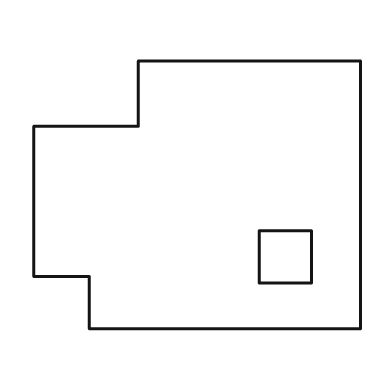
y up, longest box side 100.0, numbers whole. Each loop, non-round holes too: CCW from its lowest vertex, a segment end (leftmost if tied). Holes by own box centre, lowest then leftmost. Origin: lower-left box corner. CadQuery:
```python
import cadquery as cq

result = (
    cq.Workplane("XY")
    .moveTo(17.0, 0.0)
    .lineTo(100.0, 0.0)
    .lineTo(100.0, 82.0)
    .lineTo(32.0, 82.0)
    .lineTo(32.0, 62.0)
    .lineTo(0.0, 62.0)
    .lineTo(0.0, 16.0)
    .lineTo(17.0, 16.0)
    .close()
    .moveTo(69.0, 14.0)
    .lineTo(85.0, 14.0)
    .lineTo(85.0, 30.0)
    .lineTo(69.0, 30.0)
    .close()
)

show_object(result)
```